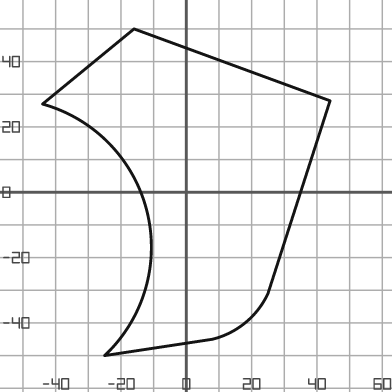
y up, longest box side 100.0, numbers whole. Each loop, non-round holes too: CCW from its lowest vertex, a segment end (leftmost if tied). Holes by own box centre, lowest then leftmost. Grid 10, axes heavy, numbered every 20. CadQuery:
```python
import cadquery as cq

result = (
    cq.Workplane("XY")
    .moveTo(-25.0, -50.0)
    .lineTo(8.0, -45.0)
    .threePointArc((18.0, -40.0), (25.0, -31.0))
    .lineTo(44.0, 28.0)
    .lineTo(-16.0, 50.0)
    .lineTo(-44.0, 27.0)
    .threePointArc((-12.0, -6.0), (-25.0, -50.0))
    .close()
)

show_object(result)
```